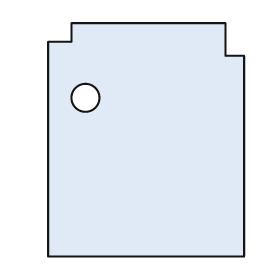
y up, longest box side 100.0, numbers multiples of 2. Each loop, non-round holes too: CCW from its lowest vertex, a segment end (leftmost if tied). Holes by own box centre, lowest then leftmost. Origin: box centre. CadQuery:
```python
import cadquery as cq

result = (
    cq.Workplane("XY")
    .moveTo(-42.0, -50.0)
    .lineTo(42.0, -50.0)
    .lineTo(42.0, 36.0)
    .lineTo(34.0, 36.0)
    .lineTo(34.0, 50.0)
    .lineTo(-32.0, 50.0)
    .lineTo(-32.0, 42.0)
    .lineTo(-42.0, 42.0)
    .close()
    .moveTo(-26.0, 18.0)
    .circle(6.0)
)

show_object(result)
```